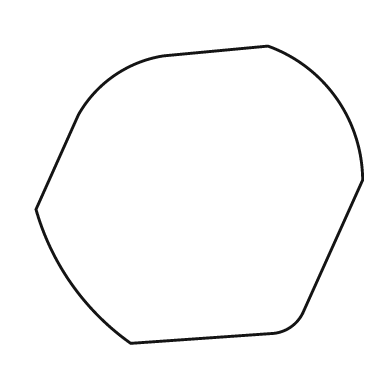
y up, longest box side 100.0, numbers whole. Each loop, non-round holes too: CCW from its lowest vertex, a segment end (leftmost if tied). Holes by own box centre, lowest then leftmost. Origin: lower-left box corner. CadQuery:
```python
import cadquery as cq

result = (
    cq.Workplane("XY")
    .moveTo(29.0, 0.0)
    .lineTo(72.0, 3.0)
    .threePointArc((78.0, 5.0), (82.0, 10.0))
    .lineTo(100.0, 50.0)
    .threePointArc((92.0, 75.0), (71.0, 91.0))
    .lineTo(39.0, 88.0)
    .threePointArc((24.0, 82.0), (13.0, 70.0))
    .lineTo(0.0, 41.0)
    .threePointArc((11.0, 18.0), (29.0, 0.0))
    .close()
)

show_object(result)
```